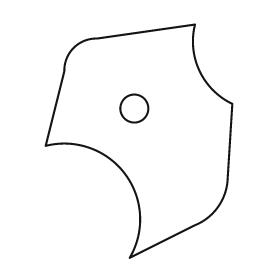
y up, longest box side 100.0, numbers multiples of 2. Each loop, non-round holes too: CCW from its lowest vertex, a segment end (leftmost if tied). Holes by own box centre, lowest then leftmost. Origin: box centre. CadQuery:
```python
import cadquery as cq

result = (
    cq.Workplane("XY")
    .moveTo(-4.0, -50.0)
    .lineTo(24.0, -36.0)
    .threePointArc((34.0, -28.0), (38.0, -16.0))
    .lineTo(40.0, 16.0)
    .threePointArc((26.0, 30.0), (24.0, 50.0))
    .lineTo(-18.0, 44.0)
    .threePointArc((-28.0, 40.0), (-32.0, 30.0))
    .lineTo(-40.0, -2.0)
    .threePointArc((-6.0, -14.0), (-4.0, -50.0))
    .close()
    .moveTo(-2.0, 14.0)
    .circle(6.0)
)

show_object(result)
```